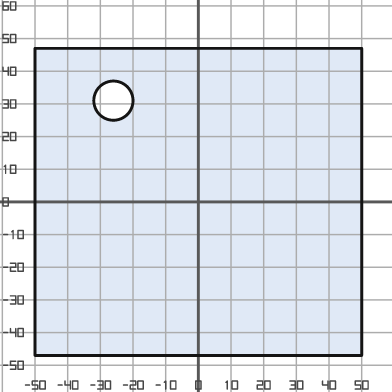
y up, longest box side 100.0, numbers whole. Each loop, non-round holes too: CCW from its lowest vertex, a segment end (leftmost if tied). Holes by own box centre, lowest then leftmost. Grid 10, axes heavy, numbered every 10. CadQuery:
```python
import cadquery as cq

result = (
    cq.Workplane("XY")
    .moveTo(-50.0, -47.0)
    .lineTo(50.0, -47.0)
    .lineTo(50.0, 47.0)
    .lineTo(-50.0, 47.0)
    .close()
    .moveTo(-26.0, 31.0)
    .circle(6.0)
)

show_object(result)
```